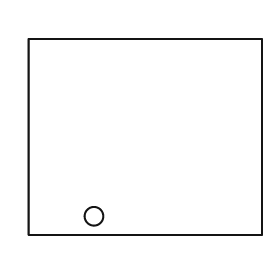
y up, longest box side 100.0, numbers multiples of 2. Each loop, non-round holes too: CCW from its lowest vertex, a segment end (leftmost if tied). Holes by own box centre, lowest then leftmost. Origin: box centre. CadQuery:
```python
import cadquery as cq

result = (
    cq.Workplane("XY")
    .moveTo(-50.0, -42.0)
    .lineTo(50.0, -42.0)
    .lineTo(50.0, 42.0)
    .lineTo(-50.0, 42.0)
    .close()
    .moveTo(-22.0, -34.0)
    .circle(4.0)
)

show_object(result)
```